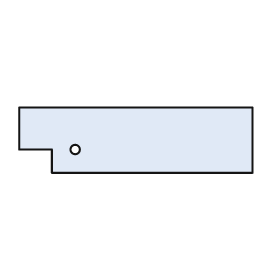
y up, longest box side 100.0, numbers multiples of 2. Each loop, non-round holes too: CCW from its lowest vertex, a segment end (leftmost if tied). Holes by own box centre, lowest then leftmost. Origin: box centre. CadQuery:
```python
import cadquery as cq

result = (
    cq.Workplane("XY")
    .moveTo(-36.0, -14.0)
    .lineTo(50.0, -14.0)
    .lineTo(50.0, 14.0)
    .lineTo(-50.0, 14.0)
    .lineTo(-50.0, -4.0)
    .lineTo(-36.0, -4.0)
    .close()
    .moveTo(-26.0, -4.0)
    .circle(2.0)
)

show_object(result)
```